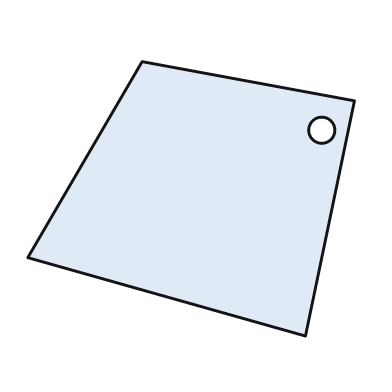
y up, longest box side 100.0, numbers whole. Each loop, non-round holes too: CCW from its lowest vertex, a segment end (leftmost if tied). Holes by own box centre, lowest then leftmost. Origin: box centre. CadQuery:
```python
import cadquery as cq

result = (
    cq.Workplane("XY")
    .moveTo(35.0, -42.0)
    .lineTo(50.0, 30.0)
    .lineTo(-15.0, 42.0)
    .lineTo(-50.0, -18.0)
    .close()
    .moveTo(40.0, 21.0)
    .circle(4.0)
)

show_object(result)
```